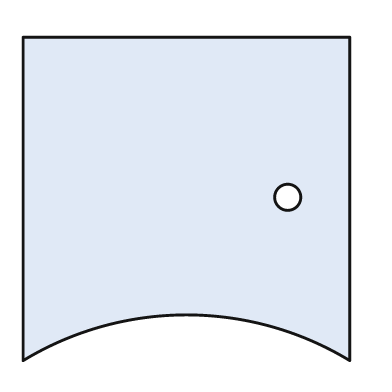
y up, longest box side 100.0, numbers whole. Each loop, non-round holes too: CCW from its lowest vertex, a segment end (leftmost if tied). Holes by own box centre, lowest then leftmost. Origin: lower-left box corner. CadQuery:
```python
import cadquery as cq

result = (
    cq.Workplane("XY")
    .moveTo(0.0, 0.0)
    .threePointArc((50.0, 14.0), (100.0, 0.0))
    .lineTo(100.0, 99.0)
    .lineTo(0.0, 99.0)
    .close()
    .moveTo(81.0, 50.0)
    .circle(4.0)
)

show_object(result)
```